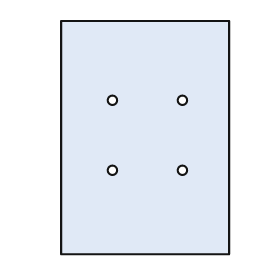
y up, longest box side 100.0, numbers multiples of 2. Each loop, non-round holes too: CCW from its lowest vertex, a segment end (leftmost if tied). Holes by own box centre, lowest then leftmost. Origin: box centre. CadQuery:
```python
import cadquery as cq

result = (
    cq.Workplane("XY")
    .moveTo(-36.0, -50.0)
    .lineTo(36.0, -50.0)
    .lineTo(36.0, 50.0)
    .lineTo(-36.0, 50.0)
    .close()
    .moveTo(-14.0, -14.0)
    .circle(2.0)
    .moveTo(16.0, -14.0)
    .circle(2.0)
    .moveTo(-14.0, 16.0)
    .circle(2.0)
    .moveTo(16.0, 16.0)
    .circle(2.0)
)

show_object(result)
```